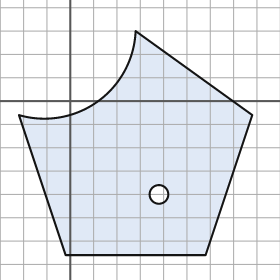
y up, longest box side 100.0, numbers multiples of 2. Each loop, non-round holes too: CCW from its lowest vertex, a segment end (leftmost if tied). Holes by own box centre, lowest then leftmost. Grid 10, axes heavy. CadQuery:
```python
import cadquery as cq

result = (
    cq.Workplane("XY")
    .moveTo(-2.0, -66.0)
    .lineTo(58.0, -66.0)
    .lineTo(78.0, -6.0)
    .lineTo(28.0, 30.0)
    .threePointArc((12.0, 0.0), (-22.0, -6.0))
    .close()
    .moveTo(38.0, -40.0)
    .circle(4.0)
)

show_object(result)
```